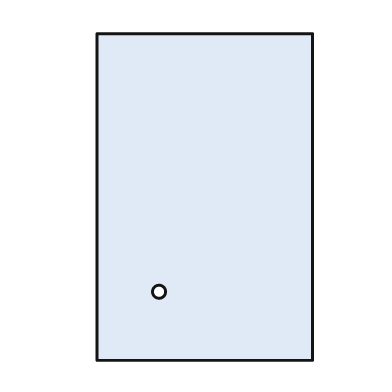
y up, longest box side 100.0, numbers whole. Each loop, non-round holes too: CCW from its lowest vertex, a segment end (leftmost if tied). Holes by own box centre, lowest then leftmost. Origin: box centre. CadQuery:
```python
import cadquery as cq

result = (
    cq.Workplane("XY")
    .moveTo(-33.0, -50.0)
    .lineTo(33.0, -50.0)
    .lineTo(33.0, 50.0)
    .lineTo(-33.0, 50.0)
    .close()
    .moveTo(-14.0, -29.0)
    .circle(2.0)
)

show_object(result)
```